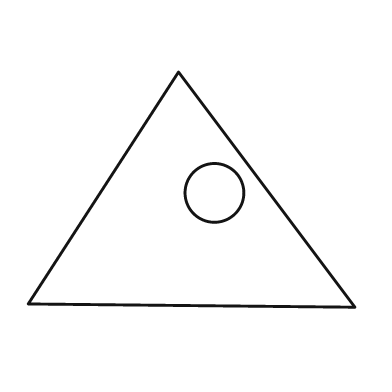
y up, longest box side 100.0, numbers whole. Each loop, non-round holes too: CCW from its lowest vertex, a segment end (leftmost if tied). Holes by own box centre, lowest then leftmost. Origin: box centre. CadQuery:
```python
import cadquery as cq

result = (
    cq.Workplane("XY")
    .moveTo(50.0, -36.0)
    .lineTo(-4.0, 36.0)
    .lineTo(-50.0, -35.0)
    .close()
    .moveTo(7.0, -1.0)
    .circle(9.0)
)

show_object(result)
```